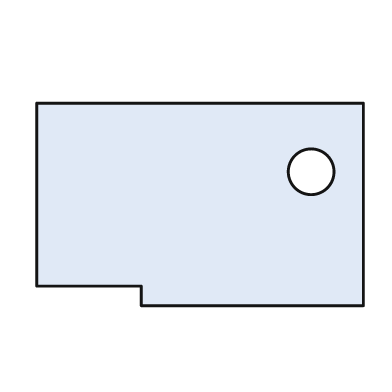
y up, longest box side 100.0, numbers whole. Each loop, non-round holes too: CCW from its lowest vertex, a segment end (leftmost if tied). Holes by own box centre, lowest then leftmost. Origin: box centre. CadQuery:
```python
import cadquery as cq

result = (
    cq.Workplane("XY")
    .moveTo(-18.0, -31.0)
    .lineTo(50.0, -31.0)
    .lineTo(50.0, 31.0)
    .lineTo(-50.0, 31.0)
    .lineTo(-50.0, -25.0)
    .lineTo(-18.0, -25.0)
    .close()
    .moveTo(34.0, 10.0)
    .circle(7.0)
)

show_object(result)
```